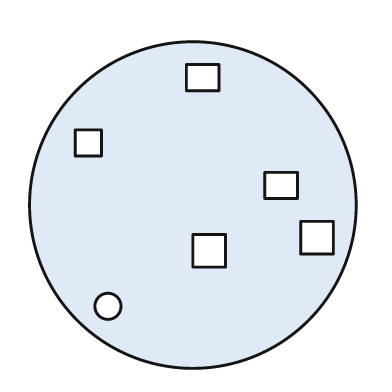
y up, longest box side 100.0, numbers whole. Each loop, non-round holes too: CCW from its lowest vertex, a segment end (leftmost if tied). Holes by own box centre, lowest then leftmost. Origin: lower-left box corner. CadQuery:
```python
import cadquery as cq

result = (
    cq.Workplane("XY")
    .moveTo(50.0, 50.0)
    .circle(50.0)
    .moveTo(24.0, 19.0)
    .circle(4.0)
    .moveTo(50.0, 31.0)
    .lineTo(60.0, 31.0)
    .lineTo(60.0, 41.0)
    .lineTo(50.0, 41.0)
    .close()
    .moveTo(83.0, 35.0)
    .lineTo(93.0, 35.0)
    .lineTo(93.0, 45.0)
    .lineTo(83.0, 45.0)
    .close()
    .moveTo(72.0, 52.0)
    .lineTo(82.0, 52.0)
    .lineTo(82.0, 60.0)
    .lineTo(72.0, 60.0)
    .close()
    .moveTo(14.0, 65.0)
    .lineTo(22.0, 65.0)
    .lineTo(22.0, 73.0)
    .lineTo(14.0, 73.0)
    .close()
    .moveTo(48.0, 85.0)
    .lineTo(58.0, 85.0)
    .lineTo(58.0, 93.0)
    .lineTo(48.0, 93.0)
    .close()
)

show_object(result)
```